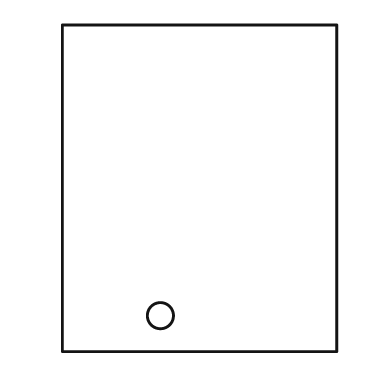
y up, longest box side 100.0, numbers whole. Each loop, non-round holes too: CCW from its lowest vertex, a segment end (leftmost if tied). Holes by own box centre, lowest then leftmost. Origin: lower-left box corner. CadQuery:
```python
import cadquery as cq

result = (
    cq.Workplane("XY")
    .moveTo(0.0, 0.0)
    .lineTo(84.0, 0.0)
    .lineTo(84.0, 100.0)
    .lineTo(0.0, 100.0)
    .close()
    .moveTo(30.0, 11.0)
    .circle(4.0)
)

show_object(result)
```